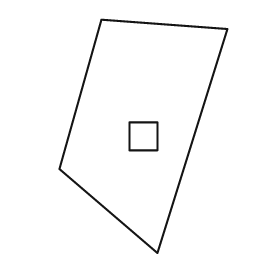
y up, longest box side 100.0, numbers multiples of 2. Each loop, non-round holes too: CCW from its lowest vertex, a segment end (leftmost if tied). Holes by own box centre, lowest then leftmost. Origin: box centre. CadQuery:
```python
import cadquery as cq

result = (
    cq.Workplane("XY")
    .moveTo(6.0, -50.0)
    .lineTo(36.0, 46.0)
    .lineTo(-18.0, 50.0)
    .lineTo(-36.0, -14.0)
    .close()
    .moveTo(-6.0, -6.0)
    .lineTo(6.0, -6.0)
    .lineTo(6.0, 6.0)
    .lineTo(-6.0, 6.0)
    .close()
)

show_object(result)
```